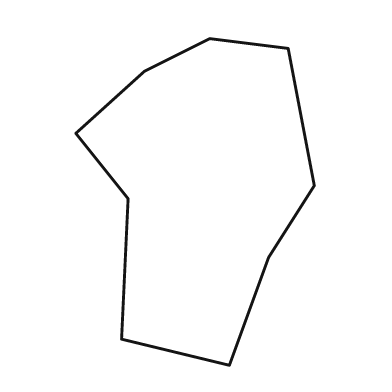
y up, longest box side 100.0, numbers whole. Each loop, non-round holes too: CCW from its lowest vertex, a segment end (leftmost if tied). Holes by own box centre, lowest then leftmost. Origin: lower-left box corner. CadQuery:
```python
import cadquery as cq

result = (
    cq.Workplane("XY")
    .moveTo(47.0, 0.0)
    .lineTo(59.0, 33.0)
    .lineTo(73.0, 55.0)
    .lineTo(65.0, 97.0)
    .lineTo(41.0, 100.0)
    .lineTo(21.0, 90.0)
    .lineTo(0.0, 71.0)
    .lineTo(16.0, 51.0)
    .lineTo(14.0, 8.0)
    .close()
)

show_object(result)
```